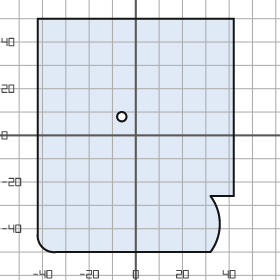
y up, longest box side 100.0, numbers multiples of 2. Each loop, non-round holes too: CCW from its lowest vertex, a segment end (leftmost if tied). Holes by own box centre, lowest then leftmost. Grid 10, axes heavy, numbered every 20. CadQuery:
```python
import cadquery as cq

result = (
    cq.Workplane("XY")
    .moveTo(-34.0, -50.0)
    .lineTo(32.0, -50.0)
    .threePointArc((36.0, -38.0), (32.0, -26.0))
    .lineTo(42.0, -26.0)
    .lineTo(42.0, 50.0)
    .lineTo(-42.0, 50.0)
    .lineTo(-42.0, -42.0)
    .threePointArc((-40.0, -48.0), (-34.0, -50.0))
    .close()
    .moveTo(-6.0, 8.0)
    .circle(2.0)
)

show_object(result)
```